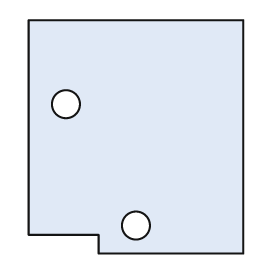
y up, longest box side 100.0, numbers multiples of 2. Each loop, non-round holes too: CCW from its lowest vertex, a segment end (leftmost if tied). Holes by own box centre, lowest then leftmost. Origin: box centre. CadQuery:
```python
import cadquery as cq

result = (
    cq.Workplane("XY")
    .moveTo(-16.0, -50.0)
    .lineTo(46.0, -50.0)
    .lineTo(46.0, 50.0)
    .lineTo(-46.0, 50.0)
    .lineTo(-46.0, -42.0)
    .lineTo(-16.0, -42.0)
    .close()
    .moveTo(0.0, -38.0)
    .circle(6.0)
    .moveTo(-30.0, 14.0)
    .circle(6.0)
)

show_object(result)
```